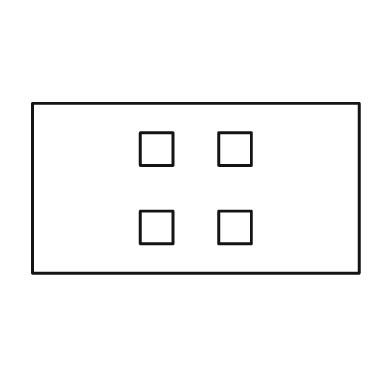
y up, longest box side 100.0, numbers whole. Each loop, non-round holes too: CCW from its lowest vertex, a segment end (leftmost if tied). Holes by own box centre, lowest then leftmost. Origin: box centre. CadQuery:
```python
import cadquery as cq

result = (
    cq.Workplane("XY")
    .moveTo(-50.0, -26.0)
    .lineTo(50.0, -26.0)
    .lineTo(50.0, 26.0)
    .lineTo(-50.0, 26.0)
    .close()
    .moveTo(-17.0, -17.0)
    .lineTo(-7.0, -17.0)
    .lineTo(-7.0, -7.0)
    .lineTo(-17.0, -7.0)
    .close()
    .moveTo(7.0, -17.0)
    .lineTo(17.0, -17.0)
    .lineTo(17.0, -7.0)
    .lineTo(7.0, -7.0)
    .close()
    .moveTo(-17.0, 7.0)
    .lineTo(-7.0, 7.0)
    .lineTo(-7.0, 17.0)
    .lineTo(-17.0, 17.0)
    .close()
    .moveTo(7.0, 7.0)
    .lineTo(17.0, 7.0)
    .lineTo(17.0, 17.0)
    .lineTo(7.0, 17.0)
    .close()
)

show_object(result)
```